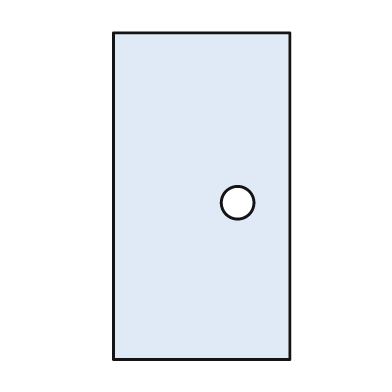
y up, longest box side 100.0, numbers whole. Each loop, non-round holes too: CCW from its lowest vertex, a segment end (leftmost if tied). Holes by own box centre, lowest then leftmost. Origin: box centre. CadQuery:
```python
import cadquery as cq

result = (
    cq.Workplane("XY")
    .moveTo(-27.0, -50.0)
    .lineTo(27.0, -50.0)
    .lineTo(27.0, 50.0)
    .lineTo(-27.0, 50.0)
    .close()
    .moveTo(11.0, -2.0)
    .circle(5.0)
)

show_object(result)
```